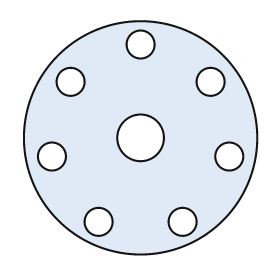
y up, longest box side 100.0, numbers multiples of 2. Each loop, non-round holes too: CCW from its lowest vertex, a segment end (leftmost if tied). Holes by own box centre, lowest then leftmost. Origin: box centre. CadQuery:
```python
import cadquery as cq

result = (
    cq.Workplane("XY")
    .moveTo(0.0, 0.0)
    .circle(50.0)
    .moveTo(-18.0, -36.0)
    .circle(6.0)
    .moveTo(18.0, -36.0)
    .circle(6.0)
    .moveTo(-38.0, -8.0)
    .circle(6.0)
    .moveTo(38.0, -8.0)
    .circle(6.0)
    .moveTo(0.0, 0.0)
    .circle(10.0)
    .moveTo(-30.0, 24.0)
    .circle(6.0)
    .moveTo(30.0, 24.0)
    .circle(6.0)
    .moveTo(0.0, 40.0)
    .circle(6.0)
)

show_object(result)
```